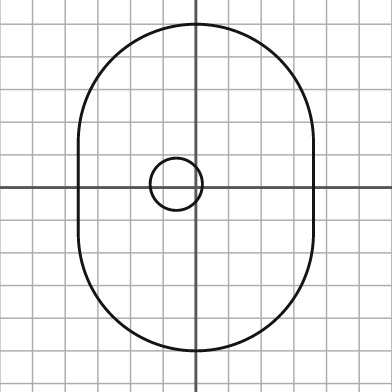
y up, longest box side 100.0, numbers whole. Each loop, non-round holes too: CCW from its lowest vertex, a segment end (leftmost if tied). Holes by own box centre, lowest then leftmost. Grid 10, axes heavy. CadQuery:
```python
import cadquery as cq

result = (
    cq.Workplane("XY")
    .moveTo(-36.0, -14.0)
    .threePointArc((0.0, -50.0), (36.0, -14.0))
    .lineTo(36.0, 14.0)
    .threePointArc((0.0, 50.0), (-36.0, 14.0))
    .close()
    .moveTo(-6.0, 1.0)
    .circle(8.0)
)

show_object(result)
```